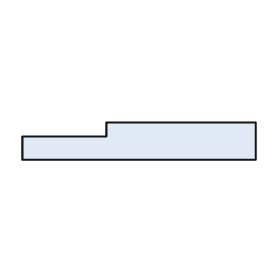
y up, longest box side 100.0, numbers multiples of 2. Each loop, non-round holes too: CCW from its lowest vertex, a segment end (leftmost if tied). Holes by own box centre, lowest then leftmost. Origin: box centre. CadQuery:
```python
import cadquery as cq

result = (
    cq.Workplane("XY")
    .moveTo(-50.0, -8.0)
    .lineTo(50.0, -8.0)
    .lineTo(50.0, 8.0)
    .lineTo(-14.0, 8.0)
    .lineTo(-14.0, 2.0)
    .lineTo(-50.0, 2.0)
    .close()
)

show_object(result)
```